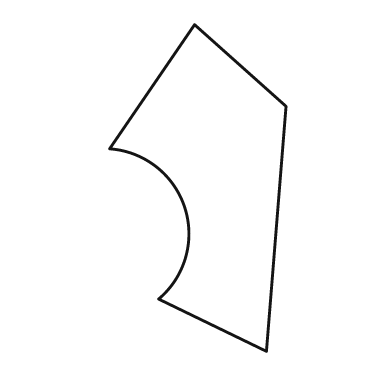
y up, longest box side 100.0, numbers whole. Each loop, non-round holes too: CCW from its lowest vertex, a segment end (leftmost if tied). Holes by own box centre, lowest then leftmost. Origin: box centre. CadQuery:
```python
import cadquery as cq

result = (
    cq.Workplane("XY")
    .moveTo(21.0, -50.0)
    .lineTo(27.0, 25.0)
    .lineTo(-1.0, 50.0)
    .lineTo(-27.0, 12.0)
    .threePointArc((-4.0, -6.0), (-12.0, -34.0))
    .close()
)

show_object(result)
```